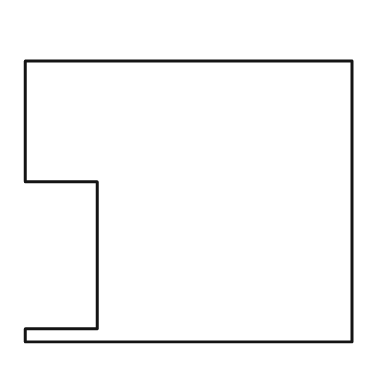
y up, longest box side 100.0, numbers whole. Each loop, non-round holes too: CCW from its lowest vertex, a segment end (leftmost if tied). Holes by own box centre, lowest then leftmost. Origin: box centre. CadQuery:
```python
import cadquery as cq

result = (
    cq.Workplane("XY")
    .moveTo(-50.0, -43.0)
    .lineTo(50.0, -43.0)
    .lineTo(50.0, 43.0)
    .lineTo(-50.0, 43.0)
    .lineTo(-50.0, 6.0)
    .lineTo(-28.0, 6.0)
    .lineTo(-28.0, -39.0)
    .lineTo(-50.0, -39.0)
    .close()
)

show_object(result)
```